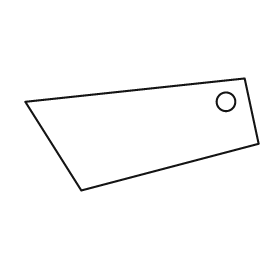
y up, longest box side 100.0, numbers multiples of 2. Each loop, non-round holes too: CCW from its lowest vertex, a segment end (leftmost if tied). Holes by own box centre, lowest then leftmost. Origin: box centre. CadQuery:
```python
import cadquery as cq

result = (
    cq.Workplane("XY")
    .moveTo(-26.0, -24.0)
    .lineTo(50.0, -4.0)
    .lineTo(44.0, 24.0)
    .lineTo(-50.0, 14.0)
    .close()
    .moveTo(36.0, 14.0)
    .circle(4.0)
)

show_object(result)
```